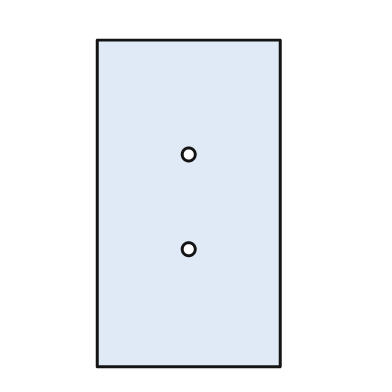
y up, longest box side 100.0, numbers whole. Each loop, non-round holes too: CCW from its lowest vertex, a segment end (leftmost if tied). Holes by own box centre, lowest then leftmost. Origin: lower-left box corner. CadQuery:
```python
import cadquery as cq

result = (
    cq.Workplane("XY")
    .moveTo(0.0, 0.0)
    .lineTo(56.0, 0.0)
    .lineTo(56.0, 100.0)
    .lineTo(0.0, 100.0)
    .close()
    .moveTo(28.0, 36.0)
    .circle(2.0)
    .moveTo(28.0, 65.0)
    .circle(2.0)
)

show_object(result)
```